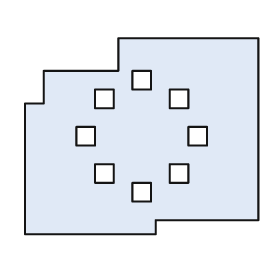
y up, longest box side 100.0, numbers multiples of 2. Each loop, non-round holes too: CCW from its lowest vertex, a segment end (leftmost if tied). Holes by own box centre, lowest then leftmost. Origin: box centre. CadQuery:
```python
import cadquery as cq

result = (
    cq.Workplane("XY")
    .moveTo(-50.0, -42.0)
    .lineTo(6.0, -42.0)
    .lineTo(6.0, -36.0)
    .lineTo(50.0, -36.0)
    .lineTo(50.0, 42.0)
    .lineTo(-10.0, 42.0)
    .lineTo(-10.0, 28.0)
    .lineTo(-42.0, 28.0)
    .lineTo(-42.0, 14.0)
    .lineTo(-50.0, 14.0)
    .close()
    .moveTo(-4.0, -28.0)
    .lineTo(4.0, -28.0)
    .lineTo(4.0, -20.0)
    .lineTo(-4.0, -20.0)
    .close()
    .moveTo(-20.0, -20.0)
    .lineTo(-12.0, -20.0)
    .lineTo(-12.0, -12.0)
    .lineTo(-20.0, -12.0)
    .close()
    .moveTo(12.0, -20.0)
    .lineTo(20.0, -20.0)
    .lineTo(20.0, -12.0)
    .lineTo(12.0, -12.0)
    .close()
    .moveTo(-28.0, -4.0)
    .lineTo(-20.0, -4.0)
    .lineTo(-20.0, 4.0)
    .lineTo(-28.0, 4.0)
    .close()
    .moveTo(20.0, -4.0)
    .lineTo(28.0, -4.0)
    .lineTo(28.0, 4.0)
    .lineTo(20.0, 4.0)
    .close()
    .moveTo(-20.0, 12.0)
    .lineTo(-12.0, 12.0)
    .lineTo(-12.0, 20.0)
    .lineTo(-20.0, 20.0)
    .close()
    .moveTo(12.0, 12.0)
    .lineTo(20.0, 12.0)
    .lineTo(20.0, 20.0)
    .lineTo(12.0, 20.0)
    .close()
    .moveTo(-4.0, 20.0)
    .lineTo(4.0, 20.0)
    .lineTo(4.0, 28.0)
    .lineTo(-4.0, 28.0)
    .close()
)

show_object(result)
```